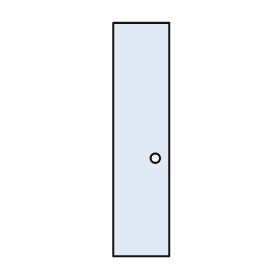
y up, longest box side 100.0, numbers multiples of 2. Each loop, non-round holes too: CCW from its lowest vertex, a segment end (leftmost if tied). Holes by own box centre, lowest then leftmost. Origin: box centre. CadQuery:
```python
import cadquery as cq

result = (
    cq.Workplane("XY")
    .moveTo(-12.0, -50.0)
    .lineTo(12.0, -50.0)
    .lineTo(12.0, 50.0)
    .lineTo(-12.0, 50.0)
    .close()
    .moveTo(6.0, -8.0)
    .circle(2.0)
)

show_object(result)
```